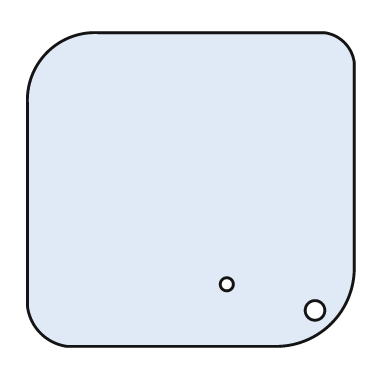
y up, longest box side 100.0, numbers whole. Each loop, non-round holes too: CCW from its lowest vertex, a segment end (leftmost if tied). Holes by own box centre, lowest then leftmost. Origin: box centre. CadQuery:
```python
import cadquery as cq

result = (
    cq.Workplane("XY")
    .moveTo(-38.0, -48.0)
    .lineTo(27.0, -48.0)
    .threePointArc((43.0, -41.0), (50.0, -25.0))
    .lineTo(50.0, 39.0)
    .threePointArc((47.0, 45.0), (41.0, 48.0))
    .lineTo(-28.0, 48.0)
    .threePointArc((-44.0, 42.0), (-50.0, 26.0))
    .lineTo(-50.0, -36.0)
    .threePointArc((-46.0, -44.0), (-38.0, -48.0))
    .close()
    .moveTo(38.0, -37.0)
    .circle(3.0)
    .moveTo(11.0, -29.0)
    .circle(2.0)
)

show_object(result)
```